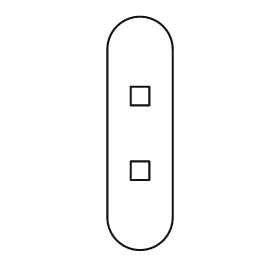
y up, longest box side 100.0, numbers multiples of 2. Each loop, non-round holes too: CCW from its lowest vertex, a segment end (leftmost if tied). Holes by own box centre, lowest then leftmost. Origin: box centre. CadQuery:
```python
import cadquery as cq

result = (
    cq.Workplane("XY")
    .moveTo(-14.0, -36.0)
    .threePointArc((0.0, -50.0), (14.0, -36.0))
    .lineTo(14.0, 36.0)
    .threePointArc((0.0, 50.0), (-14.0, 36.0))
    .close()
    .moveTo(-4.0, -20.0)
    .lineTo(4.0, -20.0)
    .lineTo(4.0, -12.0)
    .lineTo(-4.0, -12.0)
    .close()
    .moveTo(-4.0, 12.0)
    .lineTo(4.0, 12.0)
    .lineTo(4.0, 20.0)
    .lineTo(-4.0, 20.0)
    .close()
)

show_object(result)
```